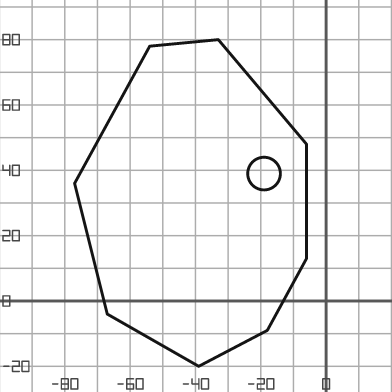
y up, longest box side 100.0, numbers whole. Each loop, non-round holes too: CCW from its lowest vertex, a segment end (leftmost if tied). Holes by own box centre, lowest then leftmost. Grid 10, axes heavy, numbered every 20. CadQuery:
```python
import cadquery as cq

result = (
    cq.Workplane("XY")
    .moveTo(-39.0, -20.0)
    .lineTo(-18.0, -9.0)
    .lineTo(-6.0, 13.0)
    .lineTo(-6.0, 48.0)
    .lineTo(-33.0, 80.0)
    .lineTo(-54.0, 78.0)
    .lineTo(-77.0, 36.0)
    .lineTo(-67.0, -4.0)
    .close()
    .moveTo(-19.0, 39.0)
    .circle(5.0)
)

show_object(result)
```